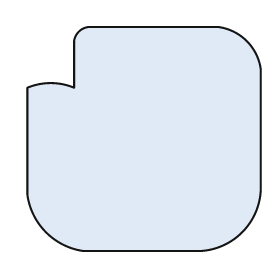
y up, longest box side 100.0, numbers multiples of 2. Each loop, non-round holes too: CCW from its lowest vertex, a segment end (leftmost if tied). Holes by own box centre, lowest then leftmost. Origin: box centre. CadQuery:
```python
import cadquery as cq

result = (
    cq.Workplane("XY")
    .moveTo(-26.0, -48.0)
    .lineTo(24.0, -48.0)
    .threePointArc((42.0, -40.0), (50.0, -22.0))
    .lineTo(50.0, 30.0)
    .threePointArc((44.0, 42.0), (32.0, 48.0))
    .lineTo(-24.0, 48.0)
    .threePointArc((-28.0, 46.0), (-30.0, 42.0))
    .lineTo(-30.0, 22.0)
    .threePointArc((-40.0, 24.0), (-50.0, 22.0))
    .lineTo(-50.0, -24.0)
    .threePointArc((-42.0, -40.0), (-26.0, -48.0))
    .close()
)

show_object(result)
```